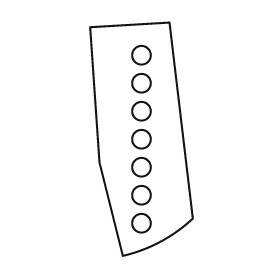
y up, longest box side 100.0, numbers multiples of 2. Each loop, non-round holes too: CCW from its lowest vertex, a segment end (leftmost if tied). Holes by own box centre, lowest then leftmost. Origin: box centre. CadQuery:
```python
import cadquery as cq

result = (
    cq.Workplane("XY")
    .moveTo(-8.0, -50.0)
    .threePointArc((8.0, -44.0), (22.0, -34.0))
    .lineTo(12.0, 50.0)
    .lineTo(-22.0, 48.0)
    .lineTo(-18.0, -10.0)
    .close()
    .moveTo(0.0, -36.0)
    .circle(4.0)
    .moveTo(0.0, -24.0)
    .circle(4.0)
    .moveTo(0.0, -12.0)
    .circle(4.0)
    .moveTo(0.0, 0.0)
    .circle(4.0)
    .moveTo(0.0, 12.0)
    .circle(4.0)
    .moveTo(0.0, 24.0)
    .circle(4.0)
    .moveTo(0.0, 36.0)
    .circle(4.0)
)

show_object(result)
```